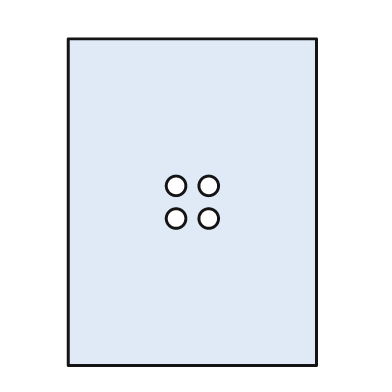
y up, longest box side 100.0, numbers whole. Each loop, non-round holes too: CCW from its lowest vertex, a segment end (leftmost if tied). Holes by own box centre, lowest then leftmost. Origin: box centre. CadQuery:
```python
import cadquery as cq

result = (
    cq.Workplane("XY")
    .moveTo(-38.0, -50.0)
    .lineTo(38.0, -50.0)
    .lineTo(38.0, 50.0)
    .lineTo(-38.0, 50.0)
    .close()
    .moveTo(-5.0, -5.0)
    .circle(3.0)
    .moveTo(5.0, -5.0)
    .circle(3.0)
    .moveTo(-5.0, 5.0)
    .circle(3.0)
    .moveTo(5.0, 5.0)
    .circle(3.0)
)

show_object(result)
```